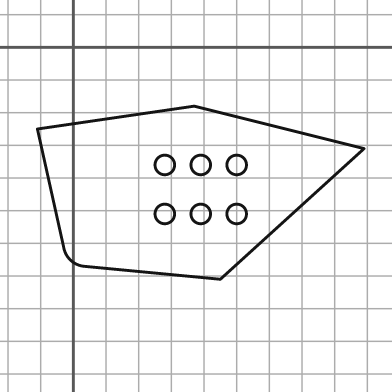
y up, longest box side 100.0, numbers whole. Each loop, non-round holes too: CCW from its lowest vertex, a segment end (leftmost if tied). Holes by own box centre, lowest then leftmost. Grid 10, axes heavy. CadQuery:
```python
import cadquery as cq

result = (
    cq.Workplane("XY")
    .moveTo(45.0, -71.0)
    .lineTo(89.0, -31.0)
    .lineTo(37.0, -18.0)
    .lineTo(-11.0, -25.0)
    .lineTo(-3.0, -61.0)
    .threePointArc((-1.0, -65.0), (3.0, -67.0))
    .close()
    .moveTo(28.0, -51.0)
    .circle(3.0)
    .moveTo(39.0, -51.0)
    .circle(3.0)
    .moveTo(50.0, -51.0)
    .circle(3.0)
    .moveTo(28.0, -36.0)
    .circle(3.0)
    .moveTo(39.0, -36.0)
    .circle(3.0)
    .moveTo(50.0, -36.0)
    .circle(3.0)
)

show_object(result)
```